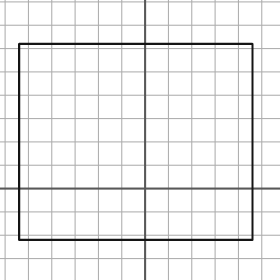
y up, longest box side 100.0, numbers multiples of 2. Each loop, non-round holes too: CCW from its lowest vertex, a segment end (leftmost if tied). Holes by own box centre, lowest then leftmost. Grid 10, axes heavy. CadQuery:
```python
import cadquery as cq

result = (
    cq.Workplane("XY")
    .moveTo(-54.0, -22.0)
    .lineTo(46.0, -22.0)
    .lineTo(46.0, 62.0)
    .lineTo(-54.0, 62.0)
    .close()
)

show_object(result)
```